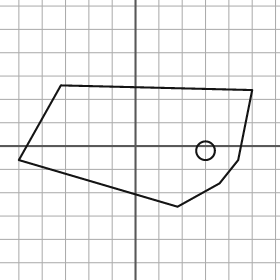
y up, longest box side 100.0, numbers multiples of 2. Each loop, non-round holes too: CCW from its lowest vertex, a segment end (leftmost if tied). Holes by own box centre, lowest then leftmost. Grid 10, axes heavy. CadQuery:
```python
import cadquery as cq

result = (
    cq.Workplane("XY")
    .moveTo(18.0, -26.0)
    .lineTo(36.0, -16.0)
    .lineTo(44.0, -6.0)
    .lineTo(50.0, 24.0)
    .lineTo(-32.0, 26.0)
    .lineTo(-50.0, -6.0)
    .close()
    .moveTo(30.0, -2.0)
    .circle(4.0)
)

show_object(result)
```